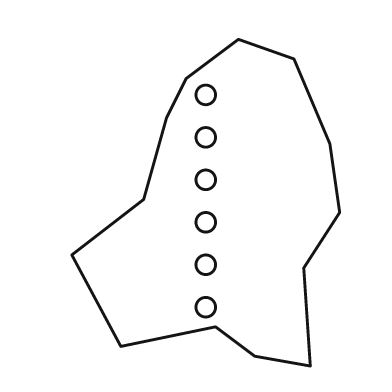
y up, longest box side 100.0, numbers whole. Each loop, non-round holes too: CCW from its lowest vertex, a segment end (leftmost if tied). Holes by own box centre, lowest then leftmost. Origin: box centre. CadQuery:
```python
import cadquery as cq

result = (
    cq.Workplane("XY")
    .moveTo(32.0, -50.0)
    .lineTo(30.0, -20.0)
    .lineTo(41.0, -3.0)
    .lineTo(38.0, 18.0)
    .lineTo(27.0, 44.0)
    .lineTo(10.0, 50.0)
    .lineTo(-6.0, 38.0)
    .lineTo(-12.0, 26.0)
    .lineTo(-19.0, 1.0)
    .lineTo(-41.0, -16.0)
    .lineTo(-26.0, -44.0)
    .lineTo(3.0, -38.0)
    .lineTo(15.0, -47.0)
    .close()
    .moveTo(0.0, -32.0)
    .circle(3.0)
    .moveTo(0.0, -19.0)
    .circle(3.0)
    .moveTo(0.0, -6.0)
    .circle(3.0)
    .moveTo(0.0, 7.0)
    .circle(3.0)
    .moveTo(0.0, 20.0)
    .circle(3.0)
    .moveTo(0.0, 33.0)
    .circle(3.0)
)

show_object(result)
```